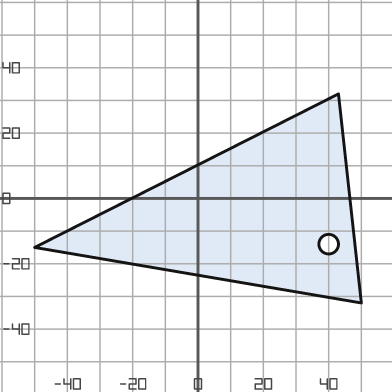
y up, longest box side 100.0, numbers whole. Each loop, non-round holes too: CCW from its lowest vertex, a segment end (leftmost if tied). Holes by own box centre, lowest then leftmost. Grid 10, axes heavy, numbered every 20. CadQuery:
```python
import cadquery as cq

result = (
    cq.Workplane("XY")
    .moveTo(50.0, -32.0)
    .lineTo(43.0, 32.0)
    .lineTo(-50.0, -15.0)
    .close()
    .moveTo(40.0, -14.0)
    .circle(3.0)
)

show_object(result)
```